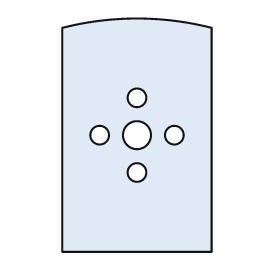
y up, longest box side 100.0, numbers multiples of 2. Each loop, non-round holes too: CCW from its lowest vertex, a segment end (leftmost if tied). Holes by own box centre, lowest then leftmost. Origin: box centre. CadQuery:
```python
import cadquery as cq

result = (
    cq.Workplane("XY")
    .moveTo(-32.0, -50.0)
    .lineTo(32.0, -50.0)
    .lineTo(32.0, 46.0)
    .threePointArc((0.0, 50.0), (-32.0, 46.0))
    .close()
    .moveTo(0.0, -16.0)
    .circle(4.0)
    .moveTo(-16.0, 0.0)
    .circle(4.0)
    .moveTo(0.0, 0.0)
    .circle(6.0)
    .moveTo(16.0, 0.0)
    .circle(4.0)
    .moveTo(0.0, 16.0)
    .circle(4.0)
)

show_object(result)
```